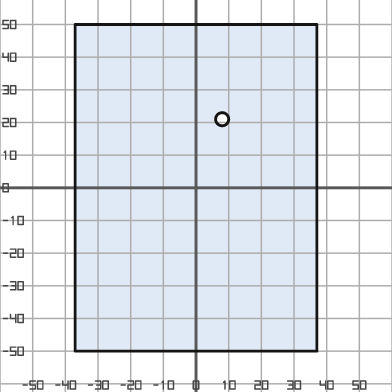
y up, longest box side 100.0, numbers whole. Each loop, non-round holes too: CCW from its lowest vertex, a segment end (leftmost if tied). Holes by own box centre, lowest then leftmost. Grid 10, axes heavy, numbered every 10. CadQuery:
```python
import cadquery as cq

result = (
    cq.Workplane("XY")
    .moveTo(-37.0, -50.0)
    .lineTo(37.0, -50.0)
    .lineTo(37.0, 50.0)
    .lineTo(-37.0, 50.0)
    .close()
    .moveTo(8.0, 21.0)
    .circle(2.0)
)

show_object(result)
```